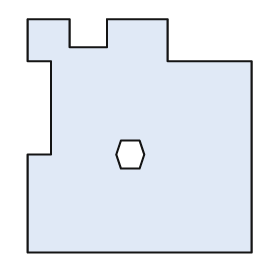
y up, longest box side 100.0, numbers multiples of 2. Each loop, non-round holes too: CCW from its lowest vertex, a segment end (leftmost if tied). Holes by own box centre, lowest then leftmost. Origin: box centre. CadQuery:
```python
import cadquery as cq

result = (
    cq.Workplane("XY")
    .moveTo(-48.0, -50.0)
    .lineTo(48.0, -50.0)
    .lineTo(48.0, 32.0)
    .lineTo(12.0, 32.0)
    .lineTo(12.0, 50.0)
    .lineTo(-14.0, 50.0)
    .lineTo(-14.0, 38.0)
    .lineTo(-30.0, 38.0)
    .lineTo(-30.0, 50.0)
    .lineTo(-48.0, 50.0)
    .lineTo(-48.0, 32.0)
    .lineTo(-38.0, 32.0)
    .lineTo(-38.0, -8.0)
    .lineTo(-48.0, -8.0)
    .close()
    .moveTo(-8.0, -14.0)
    .lineTo(0.0, -14.0)
    .lineTo(2.0, -8.0)
    .lineTo(0.0, -2.0)
    .lineTo(-8.0, -2.0)
    .lineTo(-10.0, -8.0)
    .close()
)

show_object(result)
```